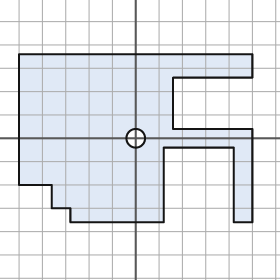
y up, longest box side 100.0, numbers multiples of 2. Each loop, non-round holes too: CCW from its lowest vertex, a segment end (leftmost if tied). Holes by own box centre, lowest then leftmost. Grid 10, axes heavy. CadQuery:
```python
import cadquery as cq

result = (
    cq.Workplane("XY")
    .moveTo(-28.0, -36.0)
    .lineTo(12.0, -36.0)
    .lineTo(12.0, -4.0)
    .lineTo(42.0, -4.0)
    .lineTo(42.0, -36.0)
    .lineTo(50.0, -36.0)
    .lineTo(50.0, 4.0)
    .lineTo(16.0, 4.0)
    .lineTo(16.0, 26.0)
    .lineTo(50.0, 26.0)
    .lineTo(50.0, 36.0)
    .lineTo(-50.0, 36.0)
    .lineTo(-50.0, -20.0)
    .lineTo(-36.0, -20.0)
    .lineTo(-36.0, -30.0)
    .lineTo(-28.0, -30.0)
    .close()
    .moveTo(0.0, 0.0)
    .circle(4.0)
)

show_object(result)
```